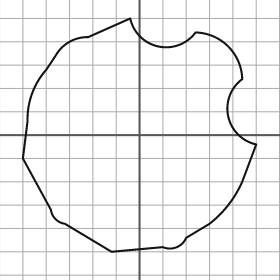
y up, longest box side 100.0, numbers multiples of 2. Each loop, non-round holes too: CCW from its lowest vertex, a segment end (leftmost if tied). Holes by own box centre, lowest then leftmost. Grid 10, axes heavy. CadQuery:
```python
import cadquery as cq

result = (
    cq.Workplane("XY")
    .moveTo(-12.0, -50.0)
    .lineTo(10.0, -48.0)
    .threePointArc((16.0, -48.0), (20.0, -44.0))
    .lineTo(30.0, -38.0)
    .threePointArc((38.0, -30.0), (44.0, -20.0))
    .lineTo(50.0, -4.0)
    .threePointArc((38.0, 8.0), (44.0, 24.0))
    .threePointArc((38.0, 38.0), (24.0, 44.0))
    .threePointArc((8.0, 38.0), (-4.0, 50.0))
    .lineTo(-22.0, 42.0)
    .threePointArc((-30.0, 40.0), (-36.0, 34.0))
    .lineTo(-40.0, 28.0)
    .threePointArc((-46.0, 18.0), (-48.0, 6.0))
    .lineTo(-50.0, -10.0)
    .lineTo(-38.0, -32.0)
    .threePointArc((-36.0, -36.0), (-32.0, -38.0))
    .close()
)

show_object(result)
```